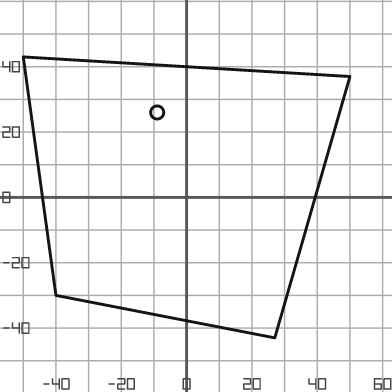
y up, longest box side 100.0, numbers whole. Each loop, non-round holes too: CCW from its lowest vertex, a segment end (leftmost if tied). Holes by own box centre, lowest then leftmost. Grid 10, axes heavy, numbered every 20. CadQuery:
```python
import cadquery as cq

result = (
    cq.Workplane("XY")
    .moveTo(27.0, -43.0)
    .lineTo(50.0, 37.0)
    .lineTo(-50.0, 43.0)
    .lineTo(-40.0, -30.0)
    .close()
    .moveTo(-9.0, 26.0)
    .circle(2.0)
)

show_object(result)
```